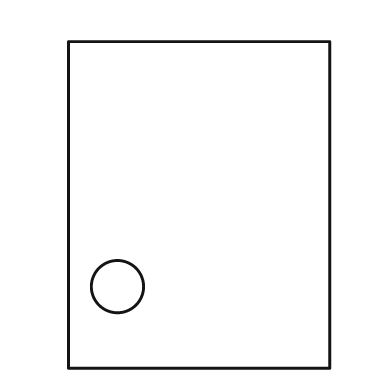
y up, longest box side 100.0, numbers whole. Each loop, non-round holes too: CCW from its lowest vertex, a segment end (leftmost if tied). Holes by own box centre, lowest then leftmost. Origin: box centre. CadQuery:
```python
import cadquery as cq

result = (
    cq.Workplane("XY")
    .moveTo(-40.0, -50.0)
    .lineTo(40.0, -50.0)
    .lineTo(40.0, 50.0)
    .lineTo(-40.0, 50.0)
    .close()
    .moveTo(-25.0, -25.0)
    .circle(8.0)
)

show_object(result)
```